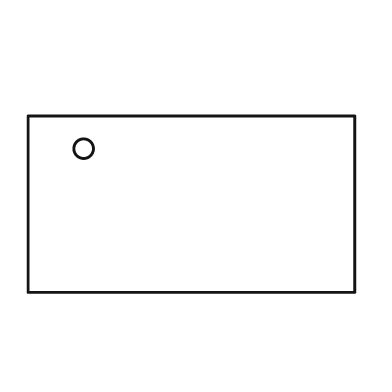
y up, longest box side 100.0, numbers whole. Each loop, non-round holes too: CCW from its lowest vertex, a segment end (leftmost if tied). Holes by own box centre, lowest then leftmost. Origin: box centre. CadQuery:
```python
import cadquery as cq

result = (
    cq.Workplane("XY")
    .moveTo(-50.0, -27.0)
    .lineTo(50.0, -27.0)
    .lineTo(50.0, 27.0)
    .lineTo(-50.0, 27.0)
    .close()
    .moveTo(-33.0, 17.0)
    .circle(3.0)
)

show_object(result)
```